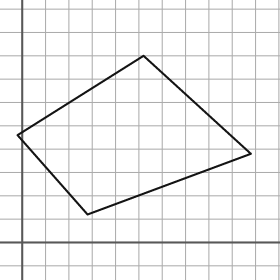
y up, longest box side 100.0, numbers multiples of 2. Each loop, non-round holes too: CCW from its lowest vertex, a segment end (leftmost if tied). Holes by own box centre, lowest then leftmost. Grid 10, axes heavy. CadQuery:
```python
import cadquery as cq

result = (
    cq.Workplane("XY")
    .moveTo(28.0, 12.0)
    .lineTo(98.0, 38.0)
    .lineTo(52.0, 80.0)
    .lineTo(-2.0, 46.0)
    .close()
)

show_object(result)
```